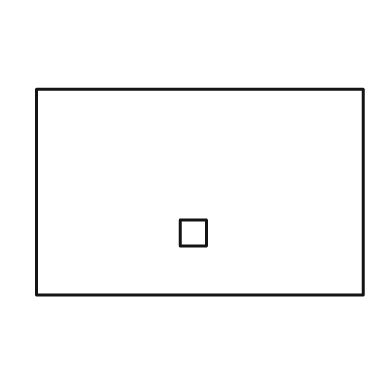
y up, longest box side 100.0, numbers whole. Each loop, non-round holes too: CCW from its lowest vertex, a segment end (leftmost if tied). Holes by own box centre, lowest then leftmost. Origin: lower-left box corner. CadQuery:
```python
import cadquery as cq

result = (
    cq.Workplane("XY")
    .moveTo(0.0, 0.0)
    .lineTo(100.0, 0.0)
    .lineTo(100.0, 63.0)
    .lineTo(0.0, 63.0)
    .close()
    .moveTo(44.0, 15.0)
    .lineTo(52.0, 15.0)
    .lineTo(52.0, 23.0)
    .lineTo(44.0, 23.0)
    .close()
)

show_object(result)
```